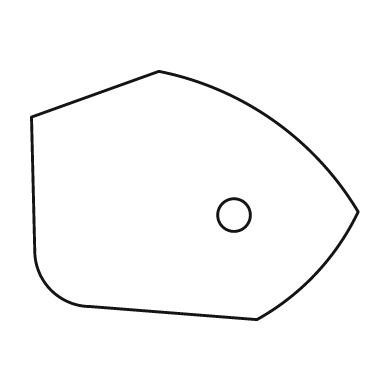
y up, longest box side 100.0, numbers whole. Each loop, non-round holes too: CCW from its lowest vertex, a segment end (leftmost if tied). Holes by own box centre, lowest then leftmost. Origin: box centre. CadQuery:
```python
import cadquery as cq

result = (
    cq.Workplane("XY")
    .moveTo(19.0, -38.0)
    .threePointArc((37.0, -24.0), (50.0, -5.0))
    .threePointArc((24.0, 23.0), (-11.0, 38.0))
    .lineTo(-50.0, 24.0)
    .lineTo(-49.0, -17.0)
    .threePointArc((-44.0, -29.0), (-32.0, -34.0))
    .close()
    .moveTo(12.0, -6.0)
    .circle(5.0)
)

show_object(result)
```